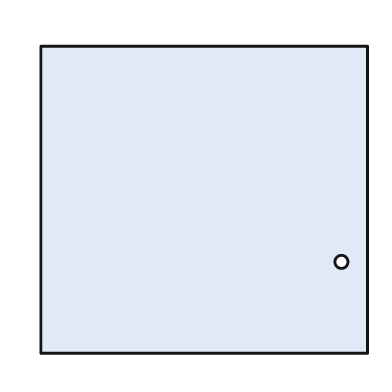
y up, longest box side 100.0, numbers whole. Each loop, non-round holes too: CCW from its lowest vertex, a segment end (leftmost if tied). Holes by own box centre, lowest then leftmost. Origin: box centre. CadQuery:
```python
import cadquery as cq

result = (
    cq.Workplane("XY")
    .moveTo(-50.0, -47.0)
    .lineTo(50.0, -47.0)
    .lineTo(50.0, 47.0)
    .lineTo(-50.0, 47.0)
    .close()
    .moveTo(42.0, -19.0)
    .circle(2.0)
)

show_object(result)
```